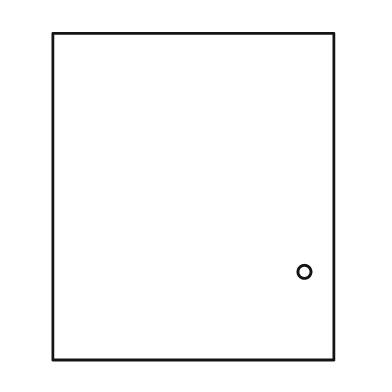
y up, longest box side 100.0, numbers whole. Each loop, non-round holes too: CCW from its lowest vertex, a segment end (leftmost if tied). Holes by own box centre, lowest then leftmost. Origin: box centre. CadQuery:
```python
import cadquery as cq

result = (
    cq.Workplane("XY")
    .moveTo(-43.0, -50.0)
    .lineTo(43.0, -50.0)
    .lineTo(43.0, 50.0)
    .lineTo(-43.0, 50.0)
    .close()
    .moveTo(34.0, -23.0)
    .circle(2.0)
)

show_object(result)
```